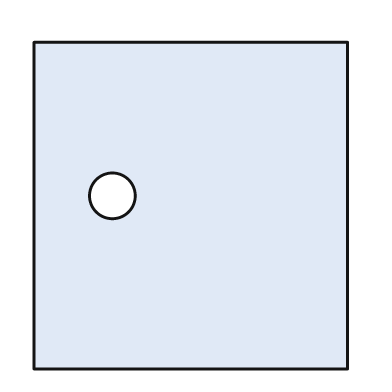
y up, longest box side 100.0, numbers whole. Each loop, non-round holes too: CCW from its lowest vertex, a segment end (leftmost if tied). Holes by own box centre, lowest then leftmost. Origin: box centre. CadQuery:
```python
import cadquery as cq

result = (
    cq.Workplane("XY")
    .moveTo(-48.0, -50.0)
    .lineTo(48.0, -50.0)
    .lineTo(48.0, 50.0)
    .lineTo(-48.0, 50.0)
    .close()
    .moveTo(-24.0, 3.0)
    .circle(7.0)
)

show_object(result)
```